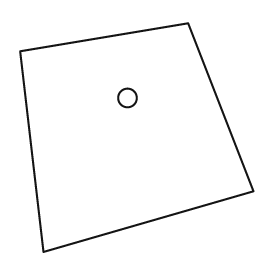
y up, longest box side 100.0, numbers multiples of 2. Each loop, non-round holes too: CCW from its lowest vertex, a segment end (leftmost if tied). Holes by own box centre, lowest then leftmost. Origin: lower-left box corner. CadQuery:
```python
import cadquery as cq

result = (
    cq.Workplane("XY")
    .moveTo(10.0, 0.0)
    .lineTo(100.0, 26.0)
    .lineTo(72.0, 98.0)
    .lineTo(0.0, 86.0)
    .close()
    .moveTo(46.0, 66.0)
    .circle(4.0)
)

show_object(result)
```